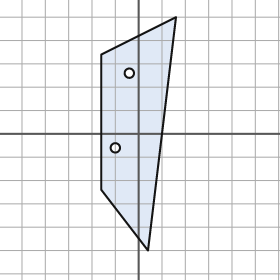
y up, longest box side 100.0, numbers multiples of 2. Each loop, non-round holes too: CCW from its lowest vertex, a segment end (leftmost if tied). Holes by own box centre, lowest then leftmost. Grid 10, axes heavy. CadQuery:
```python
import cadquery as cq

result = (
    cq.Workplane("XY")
    .moveTo(4.0, -50.0)
    .lineTo(16.0, 50.0)
    .lineTo(-16.0, 34.0)
    .lineTo(-16.0, -24.0)
    .close()
    .moveTo(-10.0, -6.0)
    .circle(2.0)
    .moveTo(-4.0, 26.0)
    .circle(2.0)
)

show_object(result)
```